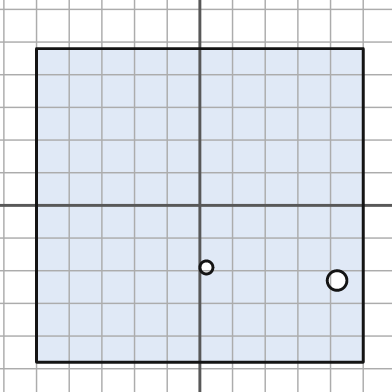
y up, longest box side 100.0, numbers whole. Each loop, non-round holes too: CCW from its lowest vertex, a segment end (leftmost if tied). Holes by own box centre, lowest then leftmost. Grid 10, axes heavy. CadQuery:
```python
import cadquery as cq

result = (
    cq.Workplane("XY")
    .moveTo(-50.0, -48.0)
    .lineTo(50.0, -48.0)
    .lineTo(50.0, 48.0)
    .lineTo(-50.0, 48.0)
    .close()
    .moveTo(42.0, -23.0)
    .circle(3.0)
    .moveTo(2.0, -19.0)
    .circle(2.0)
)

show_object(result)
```